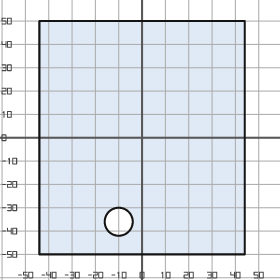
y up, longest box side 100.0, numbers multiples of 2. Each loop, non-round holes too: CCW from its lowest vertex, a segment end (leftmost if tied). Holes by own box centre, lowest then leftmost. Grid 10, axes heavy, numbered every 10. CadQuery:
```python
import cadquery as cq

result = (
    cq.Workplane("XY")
    .moveTo(-44.0, -50.0)
    .lineTo(44.0, -50.0)
    .lineTo(44.0, 50.0)
    .lineTo(-44.0, 50.0)
    .close()
    .moveTo(-10.0, -36.0)
    .circle(6.0)
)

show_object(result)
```